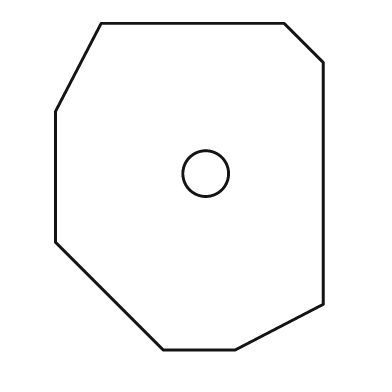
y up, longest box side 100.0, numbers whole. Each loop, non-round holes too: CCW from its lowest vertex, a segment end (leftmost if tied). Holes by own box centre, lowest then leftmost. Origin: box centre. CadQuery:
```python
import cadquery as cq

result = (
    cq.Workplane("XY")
    .moveTo(-8.0, -50.0)
    .lineTo(14.0, -50.0)
    .lineTo(41.0, -36.0)
    .lineTo(41.0, 38.0)
    .lineTo(29.0, 50.0)
    .lineTo(-27.0, 50.0)
    .lineTo(-41.0, 23.0)
    .lineTo(-41.0, -17.0)
    .close()
    .moveTo(5.0, 4.0)
    .circle(7.0)
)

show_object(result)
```